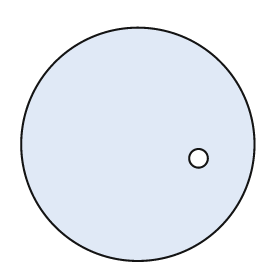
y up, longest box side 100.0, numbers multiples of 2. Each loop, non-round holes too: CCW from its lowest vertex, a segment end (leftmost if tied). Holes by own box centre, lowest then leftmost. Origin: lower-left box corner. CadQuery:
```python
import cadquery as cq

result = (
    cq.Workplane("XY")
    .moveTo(50.0, 50.0)
    .circle(50.0)
    .moveTo(76.0, 44.0)
    .circle(4.0)
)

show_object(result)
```